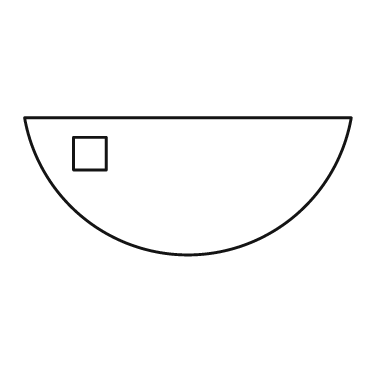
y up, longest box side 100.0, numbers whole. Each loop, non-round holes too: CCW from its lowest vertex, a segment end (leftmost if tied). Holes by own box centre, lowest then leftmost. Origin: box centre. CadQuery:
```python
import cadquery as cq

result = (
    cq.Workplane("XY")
    .moveTo(-50.0, 21.0)
    .threePointArc((0.0, -21.0), (50.0, 21.0))
    .close()
    .moveTo(-35.0, 5.0)
    .lineTo(-25.0, 5.0)
    .lineTo(-25.0, 15.0)
    .lineTo(-35.0, 15.0)
    .close()
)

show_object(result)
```